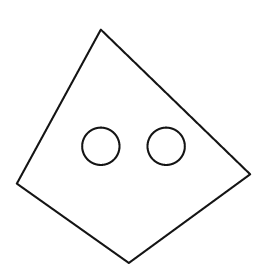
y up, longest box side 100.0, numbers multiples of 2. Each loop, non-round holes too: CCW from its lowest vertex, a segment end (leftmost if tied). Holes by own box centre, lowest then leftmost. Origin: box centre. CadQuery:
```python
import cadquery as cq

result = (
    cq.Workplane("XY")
    .moveTo(-2.0, -50.0)
    .lineTo(50.0, -12.0)
    .lineTo(-14.0, 50.0)
    .lineTo(-50.0, -16.0)
    .close()
    .moveTo(-14.0, 0.0)
    .circle(8.0)
    .moveTo(14.0, 0.0)
    .circle(8.0)
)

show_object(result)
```